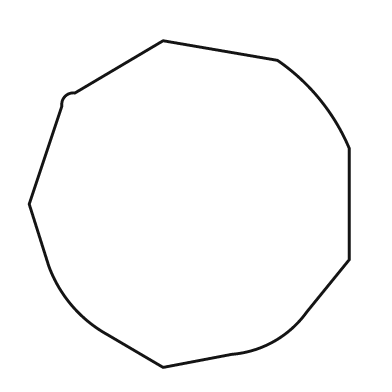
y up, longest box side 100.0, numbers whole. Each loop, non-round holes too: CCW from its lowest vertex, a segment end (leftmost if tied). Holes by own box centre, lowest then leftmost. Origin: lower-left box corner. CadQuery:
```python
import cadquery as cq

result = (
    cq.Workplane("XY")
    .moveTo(41.0, 0.0)
    .lineTo(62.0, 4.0)
    .threePointArc((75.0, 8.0), (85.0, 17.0))
    .lineTo(98.0, 33.0)
    .lineTo(98.0, 67.0)
    .threePointArc((89.0, 82.0), (76.0, 94.0))
    .lineTo(41.0, 100.0)
    .lineTo(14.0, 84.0)
    .threePointArc((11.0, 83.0), (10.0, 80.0))
    .lineTo(0.0, 50.0)
    .lineTo(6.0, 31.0)
    .threePointArc((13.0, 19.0), (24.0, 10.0))
    .close()
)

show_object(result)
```